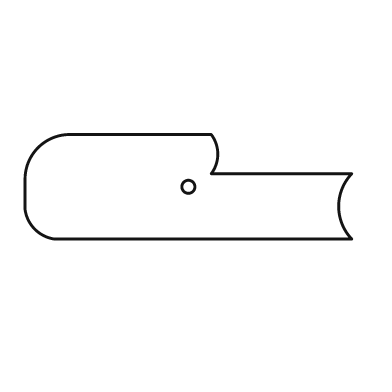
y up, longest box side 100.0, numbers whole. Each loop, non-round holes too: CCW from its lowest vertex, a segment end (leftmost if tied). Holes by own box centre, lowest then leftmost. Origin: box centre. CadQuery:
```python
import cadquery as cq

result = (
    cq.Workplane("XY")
    .moveTo(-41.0, -16.0)
    .lineTo(50.0, -16.0)
    .threePointArc((46.0, -6.0), (50.0, 4.0))
    .lineTo(7.0, 4.0)
    .threePointArc((9.0, 10.0), (7.0, 16.0))
    .lineTo(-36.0, 16.0)
    .threePointArc((-46.0, 12.0), (-50.0, 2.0))
    .lineTo(-50.0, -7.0)
    .threePointArc((-47.0, -13.0), (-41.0, -16.0))
    .close()
    .moveTo(0.0, 0.0)
    .circle(2.0)
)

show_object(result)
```